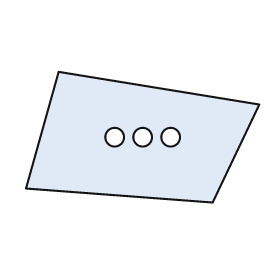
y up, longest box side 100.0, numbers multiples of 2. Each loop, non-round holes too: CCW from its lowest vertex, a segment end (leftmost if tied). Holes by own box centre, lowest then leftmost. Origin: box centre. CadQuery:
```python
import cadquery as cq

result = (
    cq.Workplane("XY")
    .moveTo(30.0, -28.0)
    .lineTo(50.0, 14.0)
    .lineTo(-36.0, 28.0)
    .lineTo(-50.0, -22.0)
    .close()
    .moveTo(-12.0, 0.0)
    .circle(4.0)
    .moveTo(0.0, 0.0)
    .circle(4.0)
    .moveTo(12.0, 0.0)
    .circle(4.0)
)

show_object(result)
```